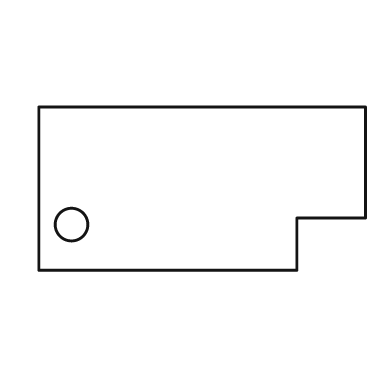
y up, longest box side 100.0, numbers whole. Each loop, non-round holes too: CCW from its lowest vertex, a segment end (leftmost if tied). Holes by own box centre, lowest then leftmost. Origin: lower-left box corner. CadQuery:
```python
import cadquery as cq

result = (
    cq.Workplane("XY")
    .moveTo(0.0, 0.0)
    .lineTo(79.0, 0.0)
    .lineTo(79.0, 16.0)
    .lineTo(100.0, 16.0)
    .lineTo(100.0, 50.0)
    .lineTo(0.0, 50.0)
    .close()
    .moveTo(10.0, 14.0)
    .circle(5.0)
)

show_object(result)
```